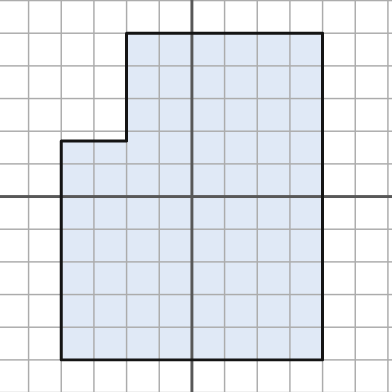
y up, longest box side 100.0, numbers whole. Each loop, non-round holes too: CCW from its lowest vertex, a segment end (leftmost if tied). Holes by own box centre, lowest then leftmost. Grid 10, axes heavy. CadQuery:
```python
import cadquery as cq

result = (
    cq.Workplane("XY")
    .moveTo(-40.0, -50.0)
    .lineTo(40.0, -50.0)
    .lineTo(40.0, 50.0)
    .lineTo(-20.0, 50.0)
    .lineTo(-20.0, 17.0)
    .lineTo(-40.0, 17.0)
    .close()
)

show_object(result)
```